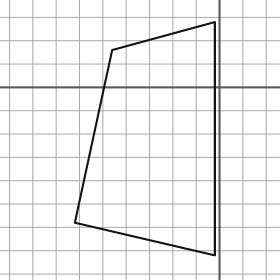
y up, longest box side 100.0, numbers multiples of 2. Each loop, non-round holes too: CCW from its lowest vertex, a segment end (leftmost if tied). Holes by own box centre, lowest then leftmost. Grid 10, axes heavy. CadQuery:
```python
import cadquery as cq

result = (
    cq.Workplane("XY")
    .moveTo(-2.0, -72.0)
    .lineTo(-2.0, 28.0)
    .lineTo(-46.0, 16.0)
    .lineTo(-62.0, -58.0)
    .close()
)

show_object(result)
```